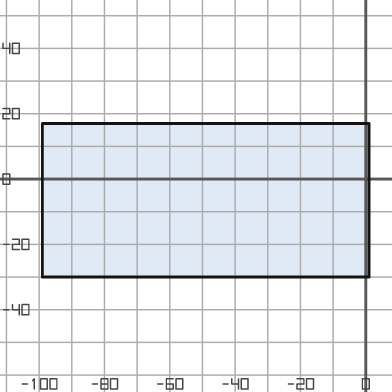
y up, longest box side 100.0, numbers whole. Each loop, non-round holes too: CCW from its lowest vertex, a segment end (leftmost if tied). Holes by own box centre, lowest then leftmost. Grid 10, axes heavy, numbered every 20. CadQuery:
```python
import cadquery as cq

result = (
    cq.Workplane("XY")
    .moveTo(-99.0, -30.0)
    .lineTo(1.0, -30.0)
    .lineTo(1.0, 17.0)
    .lineTo(-99.0, 17.0)
    .close()
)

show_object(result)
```